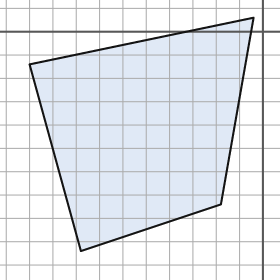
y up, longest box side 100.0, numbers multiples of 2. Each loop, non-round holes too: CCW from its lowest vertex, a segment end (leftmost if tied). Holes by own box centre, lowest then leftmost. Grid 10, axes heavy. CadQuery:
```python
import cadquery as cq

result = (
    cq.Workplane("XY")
    .moveTo(-78.0, -94.0)
    .lineTo(-18.0, -74.0)
    .lineTo(-4.0, 6.0)
    .lineTo(-100.0, -14.0)
    .close()
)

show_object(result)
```